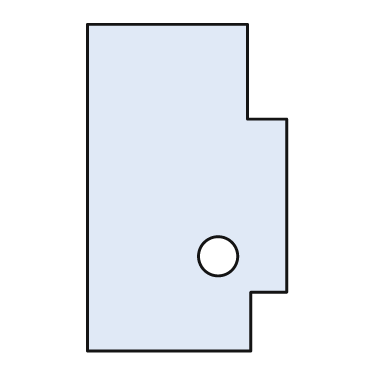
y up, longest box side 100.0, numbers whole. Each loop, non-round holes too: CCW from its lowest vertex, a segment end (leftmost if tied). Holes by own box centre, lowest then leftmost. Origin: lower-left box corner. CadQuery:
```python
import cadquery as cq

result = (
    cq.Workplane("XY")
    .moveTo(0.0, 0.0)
    .lineTo(50.0, 0.0)
    .lineTo(50.0, 18.0)
    .lineTo(61.0, 18.0)
    .lineTo(61.0, 71.0)
    .lineTo(49.0, 71.0)
    .lineTo(49.0, 100.0)
    .lineTo(0.0, 100.0)
    .close()
    .moveTo(40.0, 29.0)
    .circle(6.0)
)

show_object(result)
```